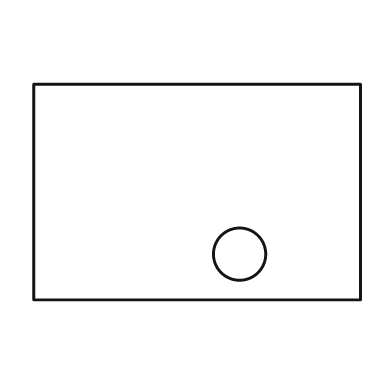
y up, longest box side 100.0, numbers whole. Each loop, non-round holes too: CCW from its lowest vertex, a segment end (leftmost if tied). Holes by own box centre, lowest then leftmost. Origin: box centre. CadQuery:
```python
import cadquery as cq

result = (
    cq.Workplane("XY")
    .moveTo(-50.0, -33.0)
    .lineTo(50.0, -33.0)
    .lineTo(50.0, 33.0)
    .lineTo(-50.0, 33.0)
    .close()
    .moveTo(13.0, -19.0)
    .circle(8.0)
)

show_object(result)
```